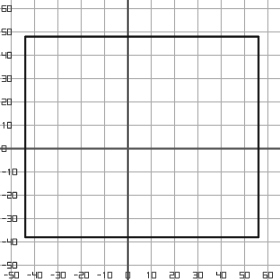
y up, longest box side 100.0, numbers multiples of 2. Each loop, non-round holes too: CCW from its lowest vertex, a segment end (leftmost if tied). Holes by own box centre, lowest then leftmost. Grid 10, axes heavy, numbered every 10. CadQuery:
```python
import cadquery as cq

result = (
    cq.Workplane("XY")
    .moveTo(-44.0, -38.0)
    .lineTo(56.0, -38.0)
    .lineTo(56.0, 48.0)
    .lineTo(-44.0, 48.0)
    .close()
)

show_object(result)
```